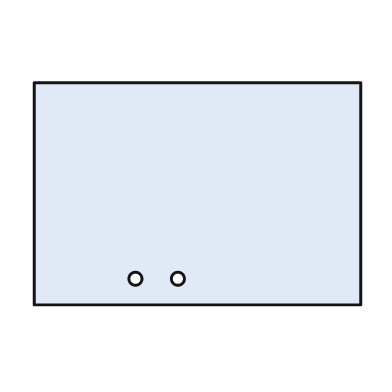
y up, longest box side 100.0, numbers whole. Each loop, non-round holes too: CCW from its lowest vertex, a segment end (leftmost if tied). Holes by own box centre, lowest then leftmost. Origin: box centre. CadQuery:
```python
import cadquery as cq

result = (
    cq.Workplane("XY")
    .moveTo(-50.0, -34.0)
    .lineTo(50.0, -34.0)
    .lineTo(50.0, 34.0)
    .lineTo(-50.0, 34.0)
    .close()
    .moveTo(-19.0, -26.0)
    .circle(2.0)
    .moveTo(-6.0, -26.0)
    .circle(2.0)
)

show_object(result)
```